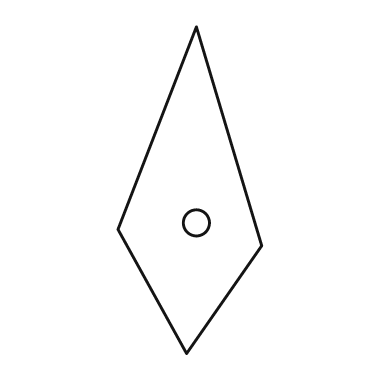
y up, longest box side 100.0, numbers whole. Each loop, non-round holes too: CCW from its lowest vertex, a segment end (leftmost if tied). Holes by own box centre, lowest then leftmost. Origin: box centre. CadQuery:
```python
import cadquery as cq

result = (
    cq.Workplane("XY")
    .moveTo(-1.0, -50.0)
    .lineTo(22.0, -17.0)
    .lineTo(2.0, 50.0)
    .lineTo(-22.0, -12.0)
    .close()
    .moveTo(2.0, -10.0)
    .circle(4.0)
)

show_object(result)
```